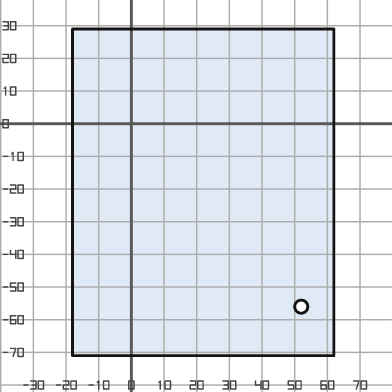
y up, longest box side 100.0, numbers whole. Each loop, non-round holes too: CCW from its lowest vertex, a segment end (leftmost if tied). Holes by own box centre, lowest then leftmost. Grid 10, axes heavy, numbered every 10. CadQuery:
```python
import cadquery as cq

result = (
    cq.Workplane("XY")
    .moveTo(-18.0, -71.0)
    .lineTo(62.0, -71.0)
    .lineTo(62.0, 29.0)
    .lineTo(-18.0, 29.0)
    .close()
    .moveTo(52.0, -56.0)
    .circle(2.0)
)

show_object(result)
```